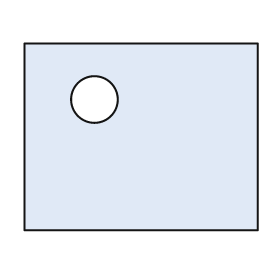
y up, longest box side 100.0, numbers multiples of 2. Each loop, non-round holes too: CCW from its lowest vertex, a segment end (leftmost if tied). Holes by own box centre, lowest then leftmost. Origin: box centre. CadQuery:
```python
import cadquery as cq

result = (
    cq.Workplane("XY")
    .moveTo(-50.0, -40.0)
    .lineTo(50.0, -40.0)
    .lineTo(50.0, 40.0)
    .lineTo(-50.0, 40.0)
    .close()
    .moveTo(-20.0, 16.0)
    .circle(10.0)
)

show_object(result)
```